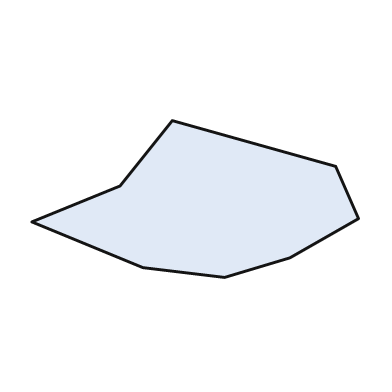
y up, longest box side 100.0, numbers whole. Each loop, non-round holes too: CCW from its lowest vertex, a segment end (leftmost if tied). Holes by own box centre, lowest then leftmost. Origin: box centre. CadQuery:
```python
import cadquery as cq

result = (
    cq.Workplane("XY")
    .moveTo(9.0, -24.0)
    .lineTo(29.0, -18.0)
    .lineTo(50.0, -6.0)
    .lineTo(43.0, 10.0)
    .lineTo(-7.0, 24.0)
    .lineTo(-23.0, 4.0)
    .lineTo(-50.0, -7.0)
    .lineTo(-16.0, -21.0)
    .close()
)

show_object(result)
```